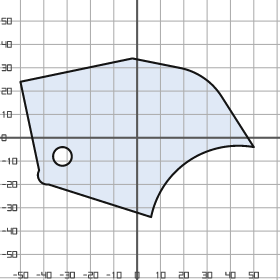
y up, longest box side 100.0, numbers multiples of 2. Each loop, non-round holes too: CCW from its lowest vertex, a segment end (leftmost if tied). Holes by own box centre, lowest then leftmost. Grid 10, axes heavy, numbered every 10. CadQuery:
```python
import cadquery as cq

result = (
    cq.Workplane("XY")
    .moveTo(6.0, -34.0)
    .threePointArc((22.0, -10.0), (50.0, -4.0))
    .lineTo(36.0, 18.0)
    .threePointArc((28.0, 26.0), (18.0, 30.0))
    .lineTo(-2.0, 34.0)
    .lineTo(-50.0, 24.0)
    .lineTo(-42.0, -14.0)
    .threePointArc((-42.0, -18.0), (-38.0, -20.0))
    .close()
    .moveTo(-32.0, -8.0)
    .circle(4.0)
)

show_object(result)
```